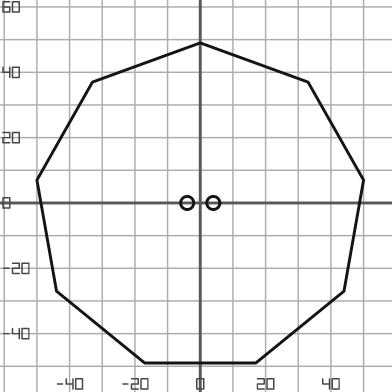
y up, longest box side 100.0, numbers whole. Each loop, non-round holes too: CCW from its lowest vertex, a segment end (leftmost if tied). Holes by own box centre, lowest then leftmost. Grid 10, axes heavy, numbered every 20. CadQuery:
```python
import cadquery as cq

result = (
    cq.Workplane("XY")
    .moveTo(-17.0, -49.0)
    .lineTo(17.0, -49.0)
    .lineTo(44.0, -27.0)
    .lineTo(50.0, 7.0)
    .lineTo(33.0, 37.0)
    .lineTo(0.0, 49.0)
    .lineTo(-33.0, 37.0)
    .lineTo(-50.0, 7.0)
    .lineTo(-44.0, -27.0)
    .close()
    .moveTo(-4.0, 0.0)
    .circle(2.0)
    .moveTo(4.0, 0.0)
    .circle(2.0)
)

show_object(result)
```